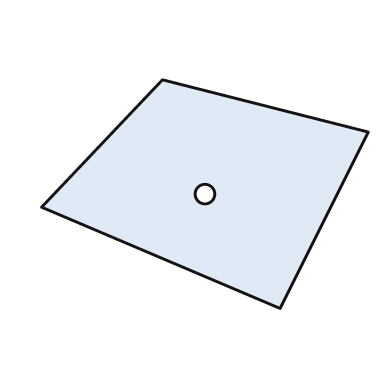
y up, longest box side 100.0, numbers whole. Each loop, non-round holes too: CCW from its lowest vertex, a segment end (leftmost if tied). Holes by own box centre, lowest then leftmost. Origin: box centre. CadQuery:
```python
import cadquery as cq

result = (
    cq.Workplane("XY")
    .moveTo(23.0, -35.0)
    .lineTo(50.0, 19.0)
    .lineTo(-13.0, 35.0)
    .lineTo(-50.0, -4.0)
    .close()
    .moveTo(0.0, 0.0)
    .circle(3.0)
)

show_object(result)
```